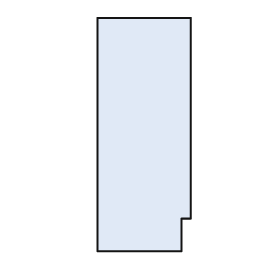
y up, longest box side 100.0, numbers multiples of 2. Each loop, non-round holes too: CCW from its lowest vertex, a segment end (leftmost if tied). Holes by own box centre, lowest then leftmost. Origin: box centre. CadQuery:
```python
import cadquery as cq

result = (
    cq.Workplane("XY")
    .moveTo(-20.0, -50.0)
    .lineTo(16.0, -50.0)
    .lineTo(16.0, -36.0)
    .lineTo(20.0, -36.0)
    .lineTo(20.0, 50.0)
    .lineTo(-20.0, 50.0)
    .close()
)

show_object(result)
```